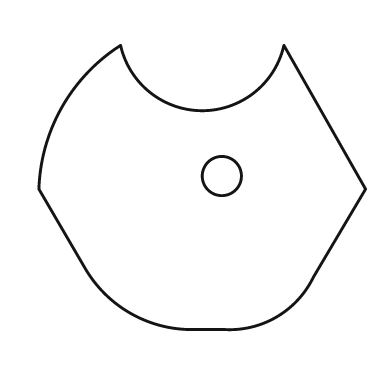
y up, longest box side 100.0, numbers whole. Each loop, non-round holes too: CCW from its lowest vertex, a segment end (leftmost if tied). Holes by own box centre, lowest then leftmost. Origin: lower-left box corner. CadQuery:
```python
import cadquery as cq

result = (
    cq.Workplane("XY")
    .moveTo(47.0, 0.0)
    .lineTo(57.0, 0.0)
    .threePointArc((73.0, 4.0), (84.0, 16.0))
    .lineTo(100.0, 43.0)
    .lineTo(75.0, 87.0)
    .threePointArc((50.0, 67.0), (25.0, 87.0))
    .threePointArc((7.0, 68.0), (0.0, 43.0))
    .lineTo(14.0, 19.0)
    .threePointArc((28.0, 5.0), (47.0, 0.0))
    .close()
    .moveTo(56.0, 47.0)
    .circle(6.0)
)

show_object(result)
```